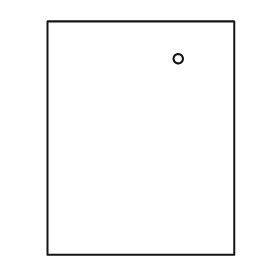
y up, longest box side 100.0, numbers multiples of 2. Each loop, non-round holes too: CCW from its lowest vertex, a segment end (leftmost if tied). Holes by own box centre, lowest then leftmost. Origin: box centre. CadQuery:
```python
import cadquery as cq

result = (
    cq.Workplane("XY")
    .moveTo(-40.0, -50.0)
    .lineTo(40.0, -50.0)
    .lineTo(40.0, 50.0)
    .lineTo(-40.0, 50.0)
    .close()
    .moveTo(16.0, 34.0)
    .circle(2.0)
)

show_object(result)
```